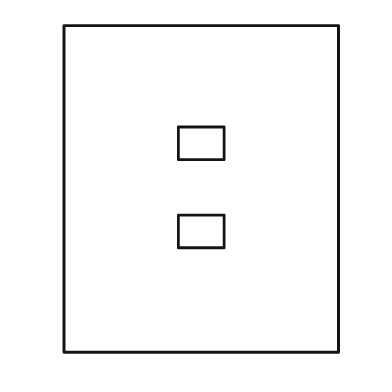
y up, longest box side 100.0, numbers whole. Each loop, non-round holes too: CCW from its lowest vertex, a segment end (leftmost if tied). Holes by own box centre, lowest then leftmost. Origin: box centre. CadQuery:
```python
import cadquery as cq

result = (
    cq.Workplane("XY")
    .moveTo(-42.0, -50.0)
    .lineTo(42.0, -50.0)
    .lineTo(42.0, 50.0)
    .lineTo(-42.0, 50.0)
    .close()
    .moveTo(-7.0, -18.0)
    .lineTo(7.0, -18.0)
    .lineTo(7.0, -8.0)
    .lineTo(-7.0, -8.0)
    .close()
    .moveTo(-7.0, 9.0)
    .lineTo(7.0, 9.0)
    .lineTo(7.0, 19.0)
    .lineTo(-7.0, 19.0)
    .close()
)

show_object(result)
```